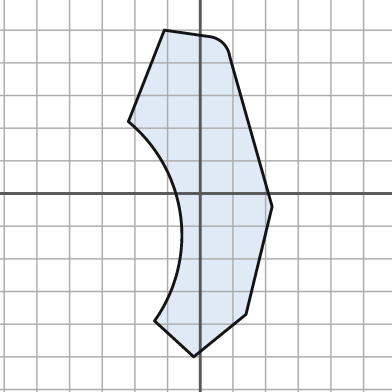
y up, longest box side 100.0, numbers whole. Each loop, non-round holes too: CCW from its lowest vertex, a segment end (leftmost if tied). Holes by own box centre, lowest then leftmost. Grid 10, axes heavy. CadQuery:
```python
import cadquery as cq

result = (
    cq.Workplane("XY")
    .moveTo(-2.0, -50.0)
    .lineTo(14.0, -37.0)
    .lineTo(22.0, -4.0)
    .lineTo(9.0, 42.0)
    .threePointArc((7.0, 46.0), (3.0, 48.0))
    .lineTo(-11.0, 50.0)
    .lineTo(-22.0, 22.0)
    .threePointArc((-6.0, -7.0), (-14.0, -39.0))
    .close()
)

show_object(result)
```